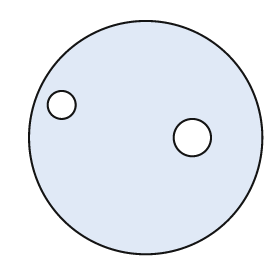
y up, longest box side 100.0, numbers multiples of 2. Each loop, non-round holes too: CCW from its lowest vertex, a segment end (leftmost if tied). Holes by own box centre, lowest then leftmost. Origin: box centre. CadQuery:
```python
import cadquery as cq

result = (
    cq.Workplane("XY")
    .moveTo(0.0, 0.0)
    .circle(50.0)
    .moveTo(20.0, 0.0)
    .circle(8.0)
    .moveTo(-36.0, 14.0)
    .circle(6.0)
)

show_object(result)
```